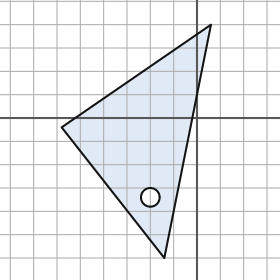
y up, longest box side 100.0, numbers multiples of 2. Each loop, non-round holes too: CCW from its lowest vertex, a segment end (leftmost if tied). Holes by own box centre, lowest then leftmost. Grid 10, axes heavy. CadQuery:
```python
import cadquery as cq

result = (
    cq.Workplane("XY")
    .moveTo(-14.0, -60.0)
    .lineTo(6.0, 40.0)
    .lineTo(-58.0, -4.0)
    .close()
    .moveTo(-20.0, -34.0)
    .circle(4.0)
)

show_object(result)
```